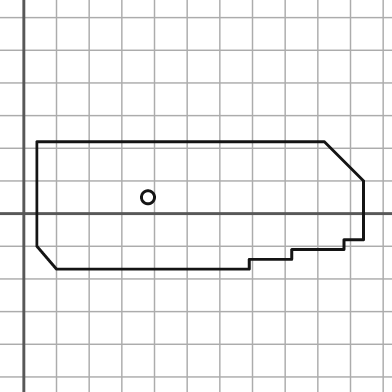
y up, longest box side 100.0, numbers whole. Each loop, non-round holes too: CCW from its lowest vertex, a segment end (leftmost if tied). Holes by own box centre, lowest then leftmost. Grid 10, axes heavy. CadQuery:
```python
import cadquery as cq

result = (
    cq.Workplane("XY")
    .moveTo(10.0, -17.0)
    .lineTo(69.0, -17.0)
    .lineTo(69.0, -14.0)
    .lineTo(82.0, -14.0)
    .lineTo(82.0, -11.0)
    .lineTo(98.0, -11.0)
    .lineTo(98.0, -8.0)
    .lineTo(104.0, -8.0)
    .lineTo(104.0, 10.0)
    .lineTo(92.0, 22.0)
    .lineTo(4.0, 22.0)
    .lineTo(4.0, -10.0)
    .close()
    .moveTo(38.0, 5.0)
    .circle(2.0)
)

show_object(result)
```